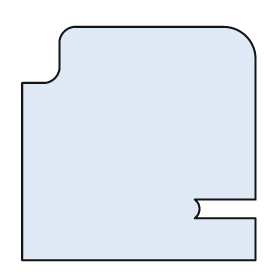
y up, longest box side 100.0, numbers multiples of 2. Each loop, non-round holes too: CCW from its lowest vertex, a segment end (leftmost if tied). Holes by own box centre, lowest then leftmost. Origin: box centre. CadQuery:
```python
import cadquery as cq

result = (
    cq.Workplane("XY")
    .moveTo(-50.0, -50.0)
    .lineTo(50.0, -50.0)
    .lineTo(50.0, -32.0)
    .lineTo(24.0, -32.0)
    .threePointArc((26.0, -28.0), (24.0, -24.0))
    .lineTo(50.0, -24.0)
    .lineTo(50.0, 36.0)
    .threePointArc((46.0, 46.0), (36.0, 50.0))
    .lineTo(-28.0, 50.0)
    .threePointArc((-32.0, 48.0), (-34.0, 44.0))
    .lineTo(-34.0, 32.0)
    .threePointArc((-36.0, 28.0), (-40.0, 26.0))
    .lineTo(-50.0, 26.0)
    .close()
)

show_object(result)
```